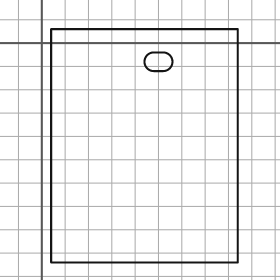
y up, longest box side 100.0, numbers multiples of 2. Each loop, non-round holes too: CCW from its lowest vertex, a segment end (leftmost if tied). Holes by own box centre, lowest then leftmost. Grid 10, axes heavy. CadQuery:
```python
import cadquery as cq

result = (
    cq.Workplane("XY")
    .moveTo(4.0, -94.0)
    .lineTo(84.0, -94.0)
    .lineTo(84.0, 6.0)
    .lineTo(4.0, 6.0)
    .close()
    .moveTo(48.0, -12.0)
    .lineTo(52.0, -12.0)
    .threePointArc((56.0, -8.0), (52.0, -4.0))
    .lineTo(48.0, -4.0)
    .threePointArc((44.0, -8.0), (48.0, -12.0))
    .close()
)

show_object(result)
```